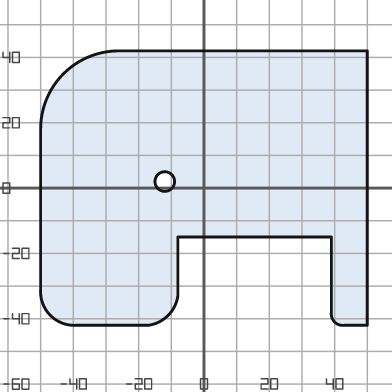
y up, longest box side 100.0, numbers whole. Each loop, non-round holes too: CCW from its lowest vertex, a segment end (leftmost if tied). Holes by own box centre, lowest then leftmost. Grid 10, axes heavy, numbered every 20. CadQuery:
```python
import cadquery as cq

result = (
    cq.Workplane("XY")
    .moveTo(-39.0, -42.0)
    .lineTo(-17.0, -42.0)
    .threePointArc((-11.0, -39.0), (-8.0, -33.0))
    .lineTo(-8.0, -15.0)
    .lineTo(39.0, -15.0)
    .lineTo(39.0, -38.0)
    .threePointArc((40.0, -41.0), (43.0, -42.0))
    .lineTo(50.0, -42.0)
    .lineTo(50.0, 42.0)
    .lineTo(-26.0, 42.0)
    .threePointArc((-43.0, 35.0), (-50.0, 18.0))
    .lineTo(-50.0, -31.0)
    .threePointArc((-47.0, -39.0), (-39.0, -42.0))
    .close()
    .moveTo(-12.0, 2.0)
    .circle(3.0)
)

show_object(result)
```